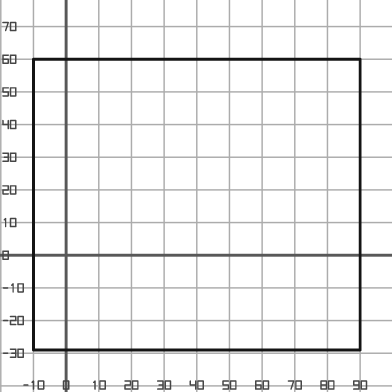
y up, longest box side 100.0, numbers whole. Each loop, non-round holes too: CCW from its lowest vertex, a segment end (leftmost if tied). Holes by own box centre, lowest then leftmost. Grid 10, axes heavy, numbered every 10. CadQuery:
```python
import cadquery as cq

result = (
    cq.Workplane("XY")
    .moveTo(-10.0, -29.0)
    .lineTo(90.0, -29.0)
    .lineTo(90.0, 60.0)
    .lineTo(-10.0, 60.0)
    .close()
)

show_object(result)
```